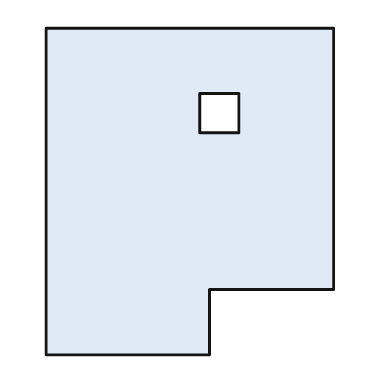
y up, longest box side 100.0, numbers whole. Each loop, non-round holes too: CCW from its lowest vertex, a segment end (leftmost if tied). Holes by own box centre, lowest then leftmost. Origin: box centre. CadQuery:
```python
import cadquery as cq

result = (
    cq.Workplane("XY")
    .moveTo(-44.0, -50.0)
    .lineTo(6.0, -50.0)
    .lineTo(6.0, -30.0)
    .lineTo(44.0, -30.0)
    .lineTo(44.0, 50.0)
    .lineTo(-44.0, 50.0)
    .close()
    .moveTo(3.0, 18.0)
    .lineTo(15.0, 18.0)
    .lineTo(15.0, 30.0)
    .lineTo(3.0, 30.0)
    .close()
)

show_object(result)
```